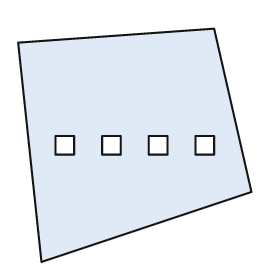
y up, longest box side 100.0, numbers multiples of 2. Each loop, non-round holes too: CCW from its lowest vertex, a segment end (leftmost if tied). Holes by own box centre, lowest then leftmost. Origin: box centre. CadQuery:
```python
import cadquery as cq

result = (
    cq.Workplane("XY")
    .moveTo(-40.0, -50.0)
    .lineTo(50.0, -20.0)
    .lineTo(34.0, 50.0)
    .lineTo(-50.0, 44.0)
    .close()
    .moveTo(-34.0, -4.0)
    .lineTo(-26.0, -4.0)
    .lineTo(-26.0, 4.0)
    .lineTo(-34.0, 4.0)
    .close()
    .moveTo(-14.0, -4.0)
    .lineTo(-6.0, -4.0)
    .lineTo(-6.0, 4.0)
    .lineTo(-14.0, 4.0)
    .close()
    .moveTo(6.0, -4.0)
    .lineTo(14.0, -4.0)
    .lineTo(14.0, 4.0)
    .lineTo(6.0, 4.0)
    .close()
    .moveTo(26.0, -4.0)
    .lineTo(34.0, -4.0)
    .lineTo(34.0, 4.0)
    .lineTo(26.0, 4.0)
    .close()
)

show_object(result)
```